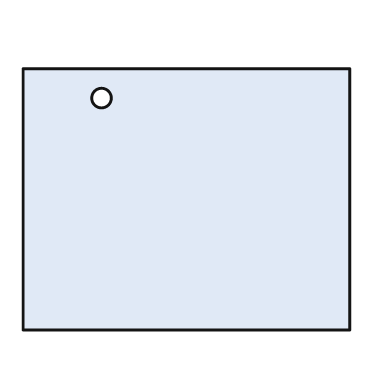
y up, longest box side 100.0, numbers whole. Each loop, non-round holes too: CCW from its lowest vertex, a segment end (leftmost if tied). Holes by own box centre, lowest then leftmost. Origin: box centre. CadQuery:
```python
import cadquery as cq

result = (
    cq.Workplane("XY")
    .moveTo(-50.0, -40.0)
    .lineTo(50.0, -40.0)
    .lineTo(50.0, 40.0)
    .lineTo(-50.0, 40.0)
    .close()
    .moveTo(-26.0, 31.0)
    .circle(3.0)
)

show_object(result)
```